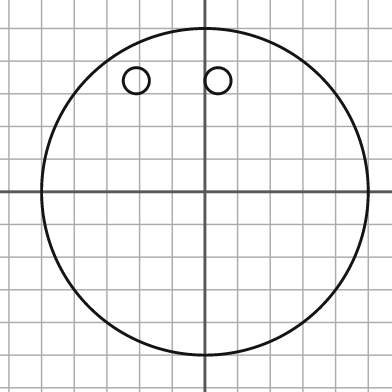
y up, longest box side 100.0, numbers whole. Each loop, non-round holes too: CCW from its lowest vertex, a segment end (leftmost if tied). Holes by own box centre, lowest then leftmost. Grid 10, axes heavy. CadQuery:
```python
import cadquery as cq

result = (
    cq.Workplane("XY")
    .moveTo(0.0, 0.0)
    .circle(50.0)
    .moveTo(-21.0, 34.0)
    .circle(4.0)
    .moveTo(4.0, 34.0)
    .circle(4.0)
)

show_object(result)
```